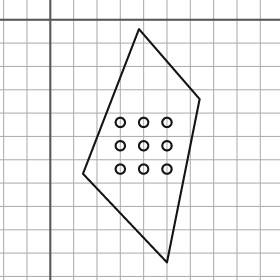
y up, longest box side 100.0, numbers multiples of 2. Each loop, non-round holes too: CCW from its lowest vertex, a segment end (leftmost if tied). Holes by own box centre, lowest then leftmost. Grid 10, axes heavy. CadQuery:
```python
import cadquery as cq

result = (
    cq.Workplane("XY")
    .moveTo(50.0, -104.0)
    .lineTo(64.0, -34.0)
    .lineTo(38.0, -4.0)
    .lineTo(14.0, -66.0)
    .close()
    .moveTo(30.0, -64.0)
    .circle(2.0)
    .moveTo(40.0, -64.0)
    .circle(2.0)
    .moveTo(50.0, -64.0)
    .circle(2.0)
    .moveTo(30.0, -54.0)
    .circle(2.0)
    .moveTo(40.0, -54.0)
    .circle(2.0)
    .moveTo(50.0, -54.0)
    .circle(2.0)
    .moveTo(30.0, -44.0)
    .circle(2.0)
    .moveTo(40.0, -44.0)
    .circle(2.0)
    .moveTo(50.0, -44.0)
    .circle(2.0)
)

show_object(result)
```